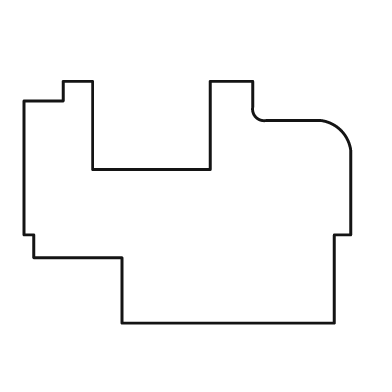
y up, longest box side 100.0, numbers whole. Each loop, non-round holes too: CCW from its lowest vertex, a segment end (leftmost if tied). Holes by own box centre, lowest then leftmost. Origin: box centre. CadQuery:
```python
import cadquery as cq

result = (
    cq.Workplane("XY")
    .moveTo(-20.0, -37.0)
    .lineTo(45.0, -37.0)
    .lineTo(45.0, -10.0)
    .lineTo(50.0, -10.0)
    .lineTo(50.0, 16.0)
    .threePointArc((47.0, 22.0), (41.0, 25.0))
    .lineTo(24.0, 25.0)
    .threePointArc((21.0, 26.0), (20.0, 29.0))
    .lineTo(20.0, 37.0)
    .lineTo(7.0, 37.0)
    .lineTo(7.0, 10.0)
    .lineTo(-29.0, 10.0)
    .lineTo(-29.0, 37.0)
    .lineTo(-38.0, 37.0)
    .lineTo(-38.0, 31.0)
    .lineTo(-50.0, 31.0)
    .lineTo(-50.0, -10.0)
    .lineTo(-47.0, -10.0)
    .lineTo(-47.0, -17.0)
    .lineTo(-20.0, -17.0)
    .close()
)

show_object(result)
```